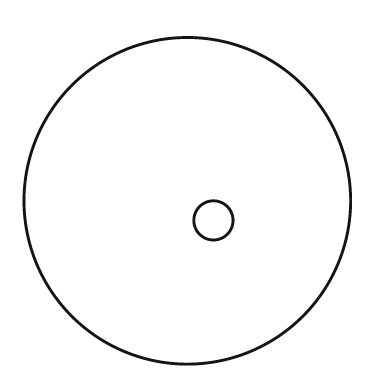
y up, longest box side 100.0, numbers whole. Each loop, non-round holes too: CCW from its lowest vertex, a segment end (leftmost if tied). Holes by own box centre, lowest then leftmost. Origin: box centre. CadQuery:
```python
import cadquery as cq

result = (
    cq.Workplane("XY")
    .moveTo(0.0, 0.0)
    .circle(50.0)
    .moveTo(8.0, -6.0)
    .circle(6.0)
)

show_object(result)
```